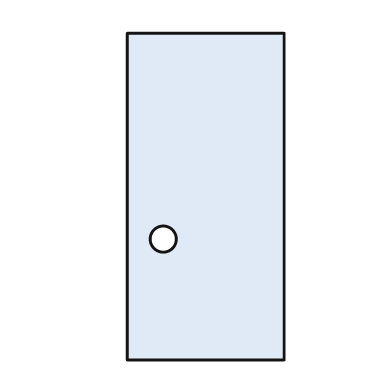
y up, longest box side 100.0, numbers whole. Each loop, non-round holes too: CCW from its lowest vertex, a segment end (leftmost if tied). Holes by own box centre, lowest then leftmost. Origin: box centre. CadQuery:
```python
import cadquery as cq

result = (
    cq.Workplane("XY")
    .moveTo(-24.0, -50.0)
    .lineTo(24.0, -50.0)
    .lineTo(24.0, 50.0)
    .lineTo(-24.0, 50.0)
    .close()
    .moveTo(-13.0, -13.0)
    .circle(4.0)
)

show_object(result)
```